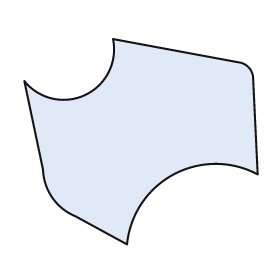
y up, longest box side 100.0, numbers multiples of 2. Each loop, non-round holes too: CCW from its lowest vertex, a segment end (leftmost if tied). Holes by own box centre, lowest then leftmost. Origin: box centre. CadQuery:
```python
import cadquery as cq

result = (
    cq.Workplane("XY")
    .moveTo(-6.0, -44.0)
    .threePointArc((14.0, -14.0), (50.0, -14.0))
    .lineTo(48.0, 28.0)
    .threePointArc((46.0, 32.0), (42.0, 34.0))
    .lineTo(-12.0, 44.0)
    .threePointArc((-24.0, 20.0), (-50.0, 26.0))
    .lineTo(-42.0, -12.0)
    .threePointArc((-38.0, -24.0), (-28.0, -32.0))
    .close()
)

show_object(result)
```